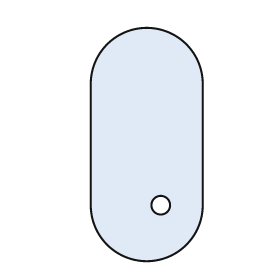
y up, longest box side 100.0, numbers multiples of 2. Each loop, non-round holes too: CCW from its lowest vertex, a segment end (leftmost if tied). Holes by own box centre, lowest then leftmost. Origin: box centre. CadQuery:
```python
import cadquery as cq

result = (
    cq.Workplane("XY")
    .moveTo(-24.0, -26.0)
    .threePointArc((0.0, -50.0), (24.0, -26.0))
    .lineTo(24.0, 26.0)
    .threePointArc((0.0, 50.0), (-24.0, 26.0))
    .close()
    .moveTo(6.0, -26.0)
    .circle(4.0)
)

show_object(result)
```